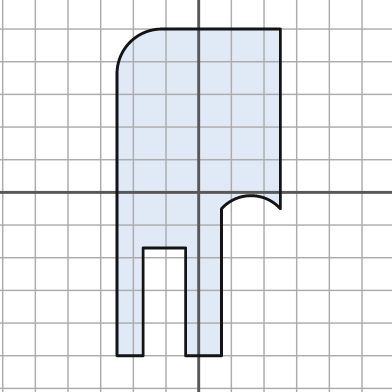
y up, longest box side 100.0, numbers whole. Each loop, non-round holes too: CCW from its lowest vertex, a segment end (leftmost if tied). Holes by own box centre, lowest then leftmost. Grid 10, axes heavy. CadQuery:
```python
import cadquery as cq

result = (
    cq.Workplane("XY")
    .moveTo(-25.0, -50.0)
    .lineTo(-17.0, -50.0)
    .lineTo(-17.0, -17.0)
    .lineTo(-4.0, -17.0)
    .lineTo(-4.0, -50.0)
    .lineTo(7.0, -50.0)
    .lineTo(7.0, -5.0)
    .threePointArc((16.0, -1.0), (25.0, -5.0))
    .lineTo(25.0, 50.0)
    .lineTo(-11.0, 50.0)
    .threePointArc((-21.0, 46.0), (-25.0, 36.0))
    .close()
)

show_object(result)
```